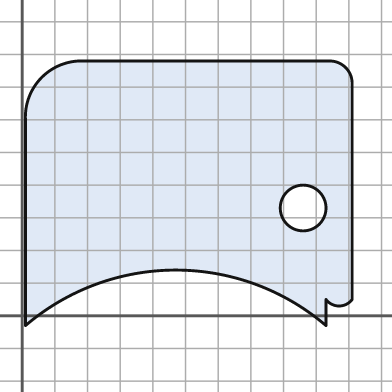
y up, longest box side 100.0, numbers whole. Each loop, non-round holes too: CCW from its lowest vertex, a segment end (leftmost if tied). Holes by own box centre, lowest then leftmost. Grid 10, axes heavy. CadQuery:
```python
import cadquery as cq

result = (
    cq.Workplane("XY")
    .moveTo(1.0, -3.0)
    .threePointArc((47.0, 14.0), (93.0, -3.0))
    .lineTo(93.0, 5.0)
    .threePointArc((97.0, 3.0), (101.0, 5.0))
    .lineTo(101.0, 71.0)
    .threePointArc((99.0, 76.0), (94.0, 78.0))
    .lineTo(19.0, 78.0)
    .threePointArc((6.0, 73.0), (1.0, 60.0))
    .close()
    .moveTo(86.0, 33.0)
    .circle(7.0)
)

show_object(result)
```